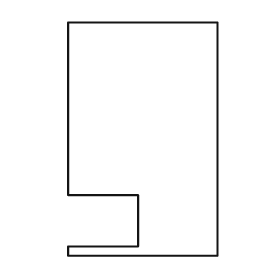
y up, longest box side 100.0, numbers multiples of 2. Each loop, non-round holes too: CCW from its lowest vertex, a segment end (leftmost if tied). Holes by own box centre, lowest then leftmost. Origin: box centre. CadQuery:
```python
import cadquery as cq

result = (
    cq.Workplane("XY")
    .moveTo(-32.0, -50.0)
    .lineTo(32.0, -50.0)
    .lineTo(32.0, 50.0)
    .lineTo(-32.0, 50.0)
    .lineTo(-32.0, -24.0)
    .lineTo(-2.0, -24.0)
    .lineTo(-2.0, -46.0)
    .lineTo(-32.0, -46.0)
    .close()
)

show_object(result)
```